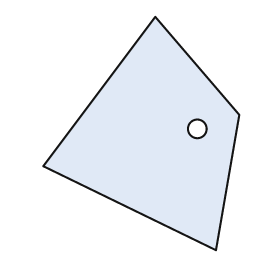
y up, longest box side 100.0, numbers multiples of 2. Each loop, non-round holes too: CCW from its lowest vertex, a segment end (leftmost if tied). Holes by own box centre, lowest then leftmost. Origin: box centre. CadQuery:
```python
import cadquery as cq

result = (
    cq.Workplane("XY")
    .moveTo(32.0, -50.0)
    .lineTo(42.0, 8.0)
    .lineTo(6.0, 50.0)
    .lineTo(-42.0, -14.0)
    .close()
    .moveTo(24.0, 2.0)
    .circle(4.0)
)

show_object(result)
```